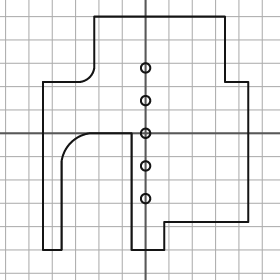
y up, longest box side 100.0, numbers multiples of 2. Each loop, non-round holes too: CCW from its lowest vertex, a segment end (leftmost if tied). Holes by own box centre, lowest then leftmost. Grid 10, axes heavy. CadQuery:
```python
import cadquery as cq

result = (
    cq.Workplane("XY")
    .moveTo(-44.0, -50.0)
    .lineTo(-36.0, -50.0)
    .lineTo(-36.0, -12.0)
    .threePointArc((-32.0, -4.0), (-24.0, 0.0))
    .lineTo(-6.0, 0.0)
    .lineTo(-6.0, -50.0)
    .lineTo(8.0, -50.0)
    .lineTo(8.0, -38.0)
    .lineTo(44.0, -38.0)
    .lineTo(44.0, 22.0)
    .lineTo(34.0, 22.0)
    .lineTo(34.0, 50.0)
    .lineTo(-22.0, 50.0)
    .lineTo(-22.0, 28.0)
    .threePointArc((-24.0, 24.0), (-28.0, 22.0))
    .lineTo(-44.0, 22.0)
    .close()
    .moveTo(0.0, -28.0)
    .circle(2.0)
    .moveTo(0.0, -14.0)
    .circle(2.0)
    .moveTo(0.0, 0.0)
    .circle(2.0)
    .moveTo(0.0, 14.0)
    .circle(2.0)
    .moveTo(0.0, 28.0)
    .circle(2.0)
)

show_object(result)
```